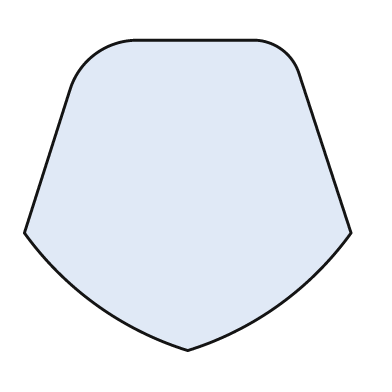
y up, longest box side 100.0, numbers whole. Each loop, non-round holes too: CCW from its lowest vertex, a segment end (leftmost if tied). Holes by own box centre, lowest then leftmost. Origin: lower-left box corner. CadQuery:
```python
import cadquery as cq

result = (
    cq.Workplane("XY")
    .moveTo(50.0, 0.0)
    .threePointArc((78.0, 14.0), (100.0, 36.0))
    .lineTo(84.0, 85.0)
    .threePointArc((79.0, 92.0), (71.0, 95.0))
    .lineTo(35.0, 95.0)
    .threePointArc((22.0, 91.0), (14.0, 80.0))
    .lineTo(0.0, 36.0)
    .threePointArc((22.0, 14.0), (50.0, 0.0))
    .close()
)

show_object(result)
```